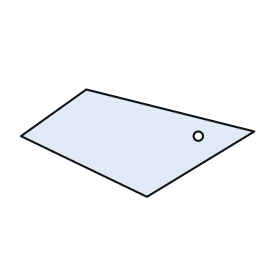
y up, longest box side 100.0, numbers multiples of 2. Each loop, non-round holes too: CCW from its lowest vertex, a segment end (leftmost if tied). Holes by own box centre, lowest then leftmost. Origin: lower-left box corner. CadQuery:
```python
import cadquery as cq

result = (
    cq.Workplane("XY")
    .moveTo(54.0, 0.0)
    .lineTo(100.0, 28.0)
    .lineTo(28.0, 46.0)
    .lineTo(0.0, 26.0)
    .close()
    .moveTo(76.0, 26.0)
    .circle(2.0)
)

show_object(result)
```